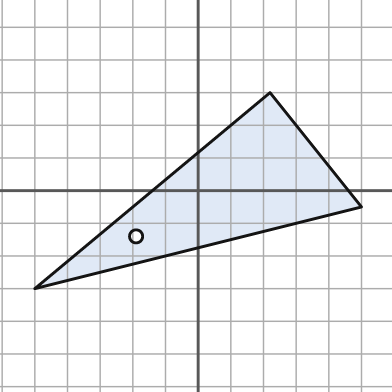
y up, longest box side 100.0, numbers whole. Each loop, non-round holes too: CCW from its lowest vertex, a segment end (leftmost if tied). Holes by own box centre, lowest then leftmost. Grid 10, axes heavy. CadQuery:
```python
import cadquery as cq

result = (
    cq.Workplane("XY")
    .moveTo(-50.0, -30.0)
    .lineTo(50.0, -5.0)
    .lineTo(22.0, 30.0)
    .close()
    .moveTo(-19.0, -14.0)
    .circle(2.0)
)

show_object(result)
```